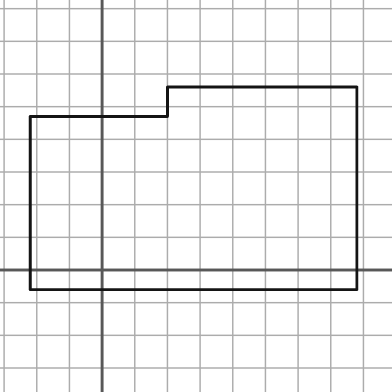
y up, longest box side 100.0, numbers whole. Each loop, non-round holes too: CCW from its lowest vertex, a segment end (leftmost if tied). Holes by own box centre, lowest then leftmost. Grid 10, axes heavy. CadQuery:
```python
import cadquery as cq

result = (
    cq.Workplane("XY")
    .moveTo(-22.0, -6.0)
    .lineTo(78.0, -6.0)
    .lineTo(78.0, 56.0)
    .lineTo(20.0, 56.0)
    .lineTo(20.0, 47.0)
    .lineTo(-22.0, 47.0)
    .close()
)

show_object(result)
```